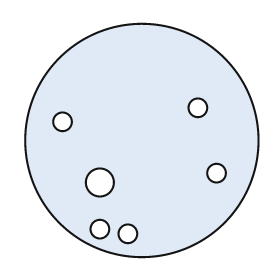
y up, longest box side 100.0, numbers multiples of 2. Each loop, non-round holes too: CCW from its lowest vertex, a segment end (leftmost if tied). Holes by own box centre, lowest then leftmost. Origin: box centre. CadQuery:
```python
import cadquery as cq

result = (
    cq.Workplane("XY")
    .moveTo(0.0, 0.0)
    .circle(50.0)
    .moveTo(-6.0, -40.0)
    .circle(4.0)
    .moveTo(-18.0, -38.0)
    .circle(4.0)
    .moveTo(-18.0, -18.0)
    .circle(6.0)
    .moveTo(32.0, -14.0)
    .circle(4.0)
    .moveTo(-34.0, 8.0)
    .circle(4.0)
    .moveTo(24.0, 14.0)
    .circle(4.0)
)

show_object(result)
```